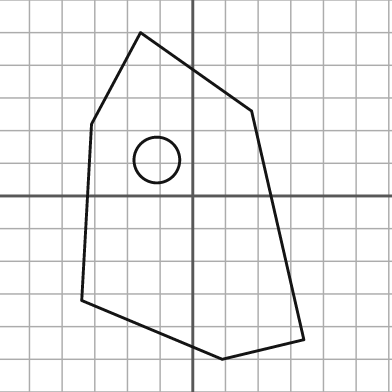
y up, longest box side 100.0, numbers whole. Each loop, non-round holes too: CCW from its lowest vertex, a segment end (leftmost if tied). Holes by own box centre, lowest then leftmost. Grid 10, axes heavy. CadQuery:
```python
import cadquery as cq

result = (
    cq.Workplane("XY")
    .moveTo(9.0, -50.0)
    .lineTo(34.0, -44.0)
    .lineTo(18.0, 26.0)
    .lineTo(-16.0, 50.0)
    .lineTo(-31.0, 22.0)
    .lineTo(-34.0, -32.0)
    .close()
    .moveTo(-11.0, 11.0)
    .circle(7.0)
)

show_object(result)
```